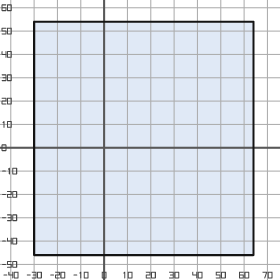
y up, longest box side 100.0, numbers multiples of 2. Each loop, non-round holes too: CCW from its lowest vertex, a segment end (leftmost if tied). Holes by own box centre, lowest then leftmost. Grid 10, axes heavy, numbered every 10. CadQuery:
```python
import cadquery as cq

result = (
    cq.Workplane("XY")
    .moveTo(-30.0, -46.0)
    .lineTo(64.0, -46.0)
    .lineTo(64.0, 54.0)
    .lineTo(-30.0, 54.0)
    .close()
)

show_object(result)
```